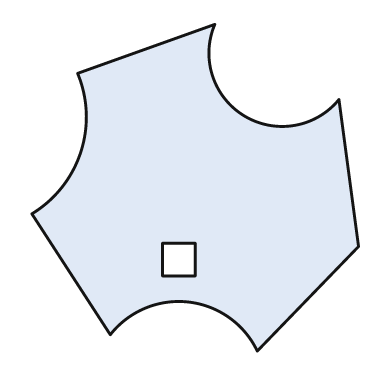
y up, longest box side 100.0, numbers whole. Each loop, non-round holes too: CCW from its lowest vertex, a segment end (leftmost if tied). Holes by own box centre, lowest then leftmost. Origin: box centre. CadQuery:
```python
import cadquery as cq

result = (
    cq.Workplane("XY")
    .moveTo(19.0, -50.0)
    .lineTo(50.0, -18.0)
    .lineTo(44.0, 27.0)
    .threePointArc((15.0, 22.0), (6.0, 50.0))
    .lineTo(-36.0, 35.0)
    .threePointArc((-35.0, 11.0), (-50.0, -8.0))
    .lineTo(-26.0, -45.0)
    .threePointArc((-2.0, -35.0), (19.0, -50.0))
    .close()
    .moveTo(-10.0, -27.0)
    .lineTo(0.0, -27.0)
    .lineTo(0.0, -17.0)
    .lineTo(-10.0, -17.0)
    .close()
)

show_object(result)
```